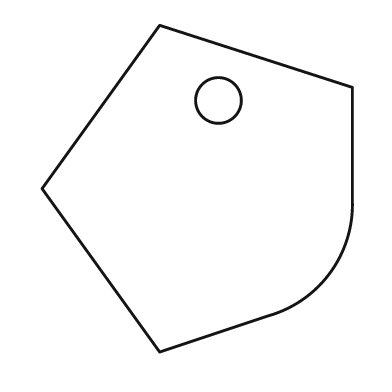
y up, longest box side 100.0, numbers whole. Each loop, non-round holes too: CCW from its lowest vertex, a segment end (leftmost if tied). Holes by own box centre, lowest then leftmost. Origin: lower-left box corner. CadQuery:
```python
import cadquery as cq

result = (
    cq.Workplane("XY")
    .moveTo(36.0, 0.0)
    .lineTo(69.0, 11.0)
    .threePointArc((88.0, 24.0), (95.0, 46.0))
    .lineTo(95.0, 81.0)
    .lineTo(36.0, 100.0)
    .lineTo(0.0, 50.0)
    .close()
    .moveTo(54.0, 77.0)
    .circle(7.0)
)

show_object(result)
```